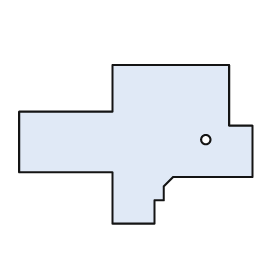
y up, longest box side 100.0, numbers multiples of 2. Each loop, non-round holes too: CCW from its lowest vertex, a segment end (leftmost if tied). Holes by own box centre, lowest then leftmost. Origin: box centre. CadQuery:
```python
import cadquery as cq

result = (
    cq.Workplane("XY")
    .moveTo(-10.0, -34.0)
    .lineTo(8.0, -34.0)
    .lineTo(8.0, -24.0)
    .lineTo(12.0, -24.0)
    .lineTo(12.0, -18.0)
    .lineTo(16.0, -14.0)
    .lineTo(50.0, -14.0)
    .lineTo(50.0, 8.0)
    .lineTo(40.0, 8.0)
    .lineTo(40.0, 34.0)
    .lineTo(-10.0, 34.0)
    .lineTo(-10.0, 14.0)
    .lineTo(-50.0, 14.0)
    .lineTo(-50.0, -12.0)
    .lineTo(-10.0, -12.0)
    .close()
    .moveTo(30.0, 2.0)
    .circle(2.0)
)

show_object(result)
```